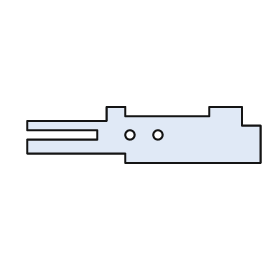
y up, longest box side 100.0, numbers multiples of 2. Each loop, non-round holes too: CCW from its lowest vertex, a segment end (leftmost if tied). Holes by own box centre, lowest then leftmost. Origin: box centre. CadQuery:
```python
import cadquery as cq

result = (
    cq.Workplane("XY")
    .moveTo(-8.0, -12.0)
    .lineTo(50.0, -12.0)
    .lineTo(50.0, 4.0)
    .lineTo(42.0, 4.0)
    .lineTo(42.0, 12.0)
    .lineTo(28.0, 12.0)
    .lineTo(28.0, 8.0)
    .lineTo(-8.0, 8.0)
    .lineTo(-8.0, 12.0)
    .lineTo(-16.0, 12.0)
    .lineTo(-16.0, 6.0)
    .lineTo(-50.0, 6.0)
    .lineTo(-50.0, 2.0)
    .lineTo(-20.0, 2.0)
    .lineTo(-20.0, -2.0)
    .lineTo(-50.0, -2.0)
    .lineTo(-50.0, -8.0)
    .lineTo(-8.0, -8.0)
    .close()
    .moveTo(-6.0, 0.0)
    .circle(2.0)
    .moveTo(6.0, 0.0)
    .circle(2.0)
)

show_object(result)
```